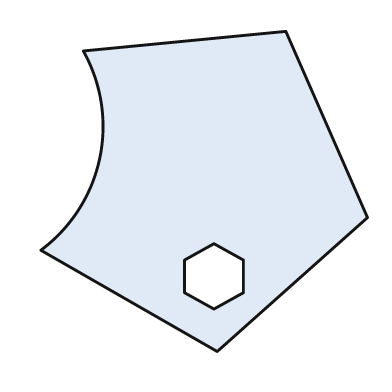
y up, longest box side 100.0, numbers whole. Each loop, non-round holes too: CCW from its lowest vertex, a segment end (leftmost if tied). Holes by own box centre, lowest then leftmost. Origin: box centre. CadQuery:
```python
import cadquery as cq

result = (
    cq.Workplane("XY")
    .moveTo(4.0, -49.0)
    .lineTo(50.0, -8.0)
    .lineTo(25.0, 49.0)
    .lineTo(-37.0, 43.0)
    .threePointArc((-32.0, 10.0), (-50.0, -18.0))
    .close()
    .moveTo(3.0, -36.0)
    .lineTo(12.0, -31.0)
    .lineTo(12.0, -21.0)
    .lineTo(3.0, -16.0)
    .lineTo(-6.0, -21.0)
    .lineTo(-6.0, -31.0)
    .close()
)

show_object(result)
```